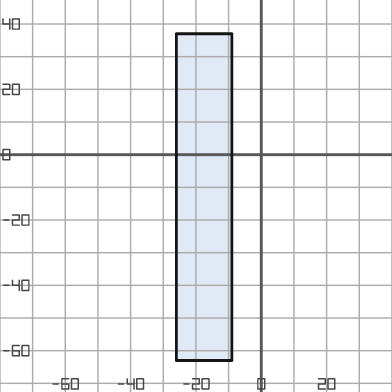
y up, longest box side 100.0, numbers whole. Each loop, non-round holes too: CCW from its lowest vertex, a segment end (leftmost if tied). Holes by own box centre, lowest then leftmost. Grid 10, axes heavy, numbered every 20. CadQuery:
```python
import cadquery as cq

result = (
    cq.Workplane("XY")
    .moveTo(-26.0, -63.0)
    .lineTo(-9.0, -63.0)
    .lineTo(-9.0, 37.0)
    .lineTo(-26.0, 37.0)
    .close()
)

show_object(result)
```